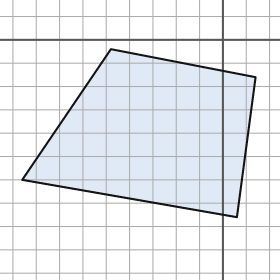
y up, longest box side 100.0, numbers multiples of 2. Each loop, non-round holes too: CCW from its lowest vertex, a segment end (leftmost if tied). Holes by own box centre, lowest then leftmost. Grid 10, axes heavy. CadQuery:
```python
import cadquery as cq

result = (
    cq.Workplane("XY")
    .moveTo(6.0, -76.0)
    .lineTo(14.0, -16.0)
    .lineTo(-48.0, -4.0)
    .lineTo(-86.0, -60.0)
    .close()
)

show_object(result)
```